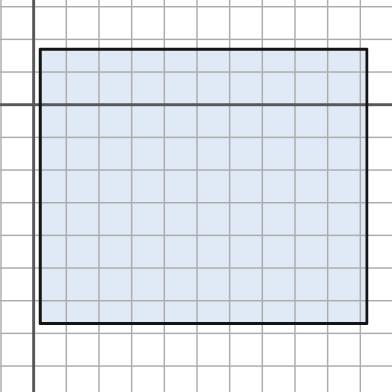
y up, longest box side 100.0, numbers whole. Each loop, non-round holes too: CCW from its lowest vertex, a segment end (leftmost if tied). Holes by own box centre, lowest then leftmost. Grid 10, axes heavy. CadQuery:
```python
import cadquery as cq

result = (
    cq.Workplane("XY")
    .moveTo(2.0, -67.0)
    .lineTo(102.0, -67.0)
    .lineTo(102.0, 17.0)
    .lineTo(2.0, 17.0)
    .close()
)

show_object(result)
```